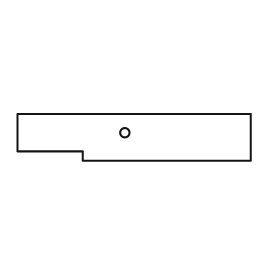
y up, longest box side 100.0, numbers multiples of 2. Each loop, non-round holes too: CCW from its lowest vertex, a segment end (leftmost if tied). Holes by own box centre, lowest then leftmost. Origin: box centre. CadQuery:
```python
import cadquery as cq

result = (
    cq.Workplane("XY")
    .moveTo(-22.0, -10.0)
    .lineTo(50.0, -10.0)
    .lineTo(50.0, 10.0)
    .lineTo(-50.0, 10.0)
    .lineTo(-50.0, -6.0)
    .lineTo(-22.0, -6.0)
    .close()
    .moveTo(-4.0, 2.0)
    .circle(2.0)
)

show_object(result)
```